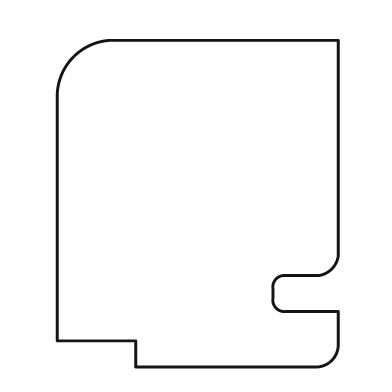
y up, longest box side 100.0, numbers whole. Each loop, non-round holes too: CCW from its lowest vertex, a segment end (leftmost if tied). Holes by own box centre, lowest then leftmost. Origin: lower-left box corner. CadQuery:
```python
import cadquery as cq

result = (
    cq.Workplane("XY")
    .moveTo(24.0, 0.0)
    .lineTo(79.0, 0.0)
    .threePointArc((84.0, 2.0), (86.0, 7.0))
    .lineTo(86.0, 17.0)
    .lineTo(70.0, 17.0)
    .threePointArc((67.0, 18.0), (66.0, 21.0))
    .lineTo(66.0, 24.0)
    .threePointArc((67.0, 27.0), (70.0, 28.0))
    .lineTo(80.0, 28.0)
    .threePointArc((84.0, 30.0), (86.0, 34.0))
    .lineTo(86.0, 100.0)
    .lineTo(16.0, 100.0)
    .threePointArc((5.0, 95.0), (0.0, 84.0))
    .lineTo(0.0, 8.0)
    .lineTo(24.0, 8.0)
    .close()
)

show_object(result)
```